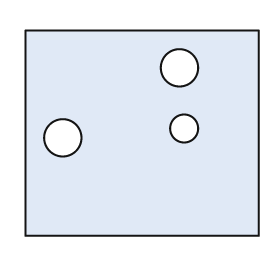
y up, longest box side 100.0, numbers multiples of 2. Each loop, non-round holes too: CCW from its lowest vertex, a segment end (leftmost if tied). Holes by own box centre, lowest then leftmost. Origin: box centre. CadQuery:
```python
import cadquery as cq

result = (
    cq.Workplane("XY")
    .moveTo(-50.0, -44.0)
    .lineTo(50.0, -44.0)
    .lineTo(50.0, 44.0)
    .lineTo(-50.0, 44.0)
    .close()
    .moveTo(-34.0, -2.0)
    .circle(8.0)
    .moveTo(18.0, 2.0)
    .circle(6.0)
    .moveTo(16.0, 28.0)
    .circle(8.0)
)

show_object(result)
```